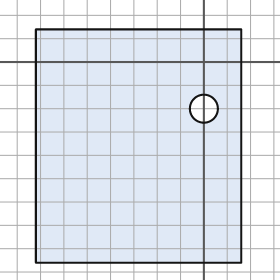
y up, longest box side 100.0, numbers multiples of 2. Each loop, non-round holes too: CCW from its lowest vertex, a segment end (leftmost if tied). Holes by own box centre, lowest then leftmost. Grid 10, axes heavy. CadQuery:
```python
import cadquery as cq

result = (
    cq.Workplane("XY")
    .moveTo(-72.0, -86.0)
    .lineTo(16.0, -86.0)
    .lineTo(16.0, 14.0)
    .lineTo(-72.0, 14.0)
    .close()
    .moveTo(0.0, -20.0)
    .circle(6.0)
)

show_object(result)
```